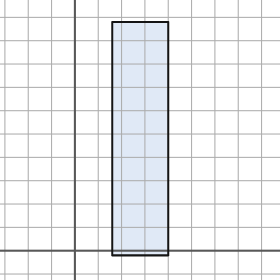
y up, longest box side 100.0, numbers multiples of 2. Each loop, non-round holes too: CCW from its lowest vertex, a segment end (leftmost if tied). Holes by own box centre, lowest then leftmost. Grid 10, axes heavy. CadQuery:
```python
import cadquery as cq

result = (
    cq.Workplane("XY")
    .moveTo(16.0, -2.0)
    .lineTo(40.0, -2.0)
    .lineTo(40.0, 98.0)
    .lineTo(16.0, 98.0)
    .close()
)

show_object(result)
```